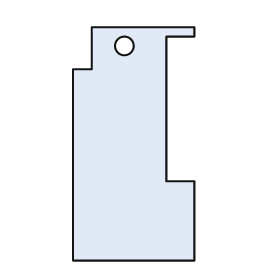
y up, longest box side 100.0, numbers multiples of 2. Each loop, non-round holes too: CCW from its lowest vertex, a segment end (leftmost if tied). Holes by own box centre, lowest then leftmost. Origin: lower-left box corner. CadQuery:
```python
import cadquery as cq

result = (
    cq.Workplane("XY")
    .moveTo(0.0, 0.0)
    .lineTo(52.0, 0.0)
    .lineTo(52.0, 34.0)
    .lineTo(40.0, 34.0)
    .lineTo(40.0, 96.0)
    .lineTo(52.0, 96.0)
    .lineTo(52.0, 100.0)
    .lineTo(8.0, 100.0)
    .lineTo(8.0, 82.0)
    .lineTo(0.0, 82.0)
    .close()
    .moveTo(22.0, 92.0)
    .circle(4.0)
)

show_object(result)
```